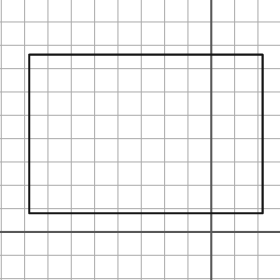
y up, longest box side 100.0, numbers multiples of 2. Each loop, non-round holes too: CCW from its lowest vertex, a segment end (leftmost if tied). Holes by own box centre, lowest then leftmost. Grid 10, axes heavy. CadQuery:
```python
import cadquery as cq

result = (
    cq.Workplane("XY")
    .moveTo(-78.0, 8.0)
    .lineTo(22.0, 8.0)
    .lineTo(22.0, 76.0)
    .lineTo(-78.0, 76.0)
    .close()
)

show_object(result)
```